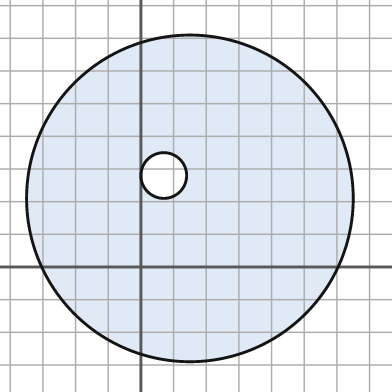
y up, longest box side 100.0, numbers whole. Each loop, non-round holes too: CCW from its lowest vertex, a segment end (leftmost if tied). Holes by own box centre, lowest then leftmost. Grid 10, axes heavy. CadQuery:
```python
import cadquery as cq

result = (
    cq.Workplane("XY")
    .moveTo(15.0, 21.0)
    .circle(50.0)
    .moveTo(7.0, 28.0)
    .circle(7.0)
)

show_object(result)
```